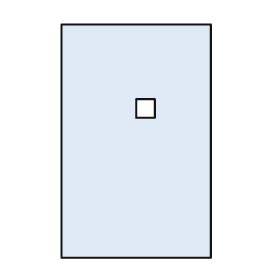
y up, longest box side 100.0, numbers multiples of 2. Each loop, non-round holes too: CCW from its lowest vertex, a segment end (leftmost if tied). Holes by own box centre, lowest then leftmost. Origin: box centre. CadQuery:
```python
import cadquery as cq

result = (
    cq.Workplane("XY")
    .moveTo(-32.0, -50.0)
    .lineTo(32.0, -50.0)
    .lineTo(32.0, 50.0)
    .lineTo(-32.0, 50.0)
    .close()
    .moveTo(0.0, 10.0)
    .lineTo(8.0, 10.0)
    .lineTo(8.0, 18.0)
    .lineTo(0.0, 18.0)
    .close()
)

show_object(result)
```